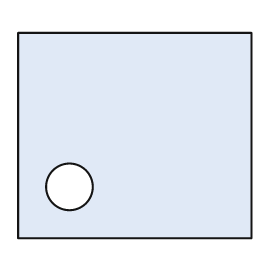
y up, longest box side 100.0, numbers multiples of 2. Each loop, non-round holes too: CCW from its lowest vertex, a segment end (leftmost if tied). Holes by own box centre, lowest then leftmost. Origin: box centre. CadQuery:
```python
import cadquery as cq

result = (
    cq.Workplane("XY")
    .moveTo(-50.0, -44.0)
    .lineTo(50.0, -44.0)
    .lineTo(50.0, 44.0)
    .lineTo(-50.0, 44.0)
    .close()
    .moveTo(-28.0, -22.0)
    .circle(10.0)
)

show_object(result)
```